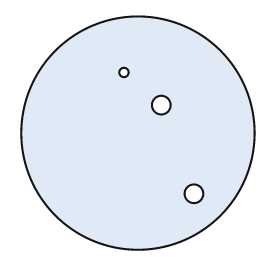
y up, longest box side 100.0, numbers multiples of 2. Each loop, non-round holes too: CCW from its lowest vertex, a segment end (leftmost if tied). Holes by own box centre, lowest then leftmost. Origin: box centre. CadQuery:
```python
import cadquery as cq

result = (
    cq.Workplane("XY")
    .moveTo(0.0, 0.0)
    .circle(50.0)
    .moveTo(24.0, -26.0)
    .circle(4.0)
    .moveTo(10.0, 12.0)
    .circle(4.0)
    .moveTo(-6.0, 26.0)
    .circle(2.0)
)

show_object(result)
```